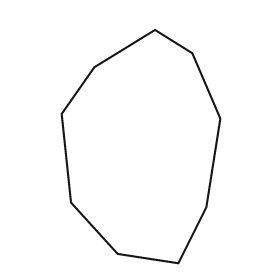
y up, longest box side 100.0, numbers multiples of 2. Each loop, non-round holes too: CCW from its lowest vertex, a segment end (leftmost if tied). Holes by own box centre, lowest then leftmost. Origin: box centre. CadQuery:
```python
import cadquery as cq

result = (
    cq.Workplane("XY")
    .moveTo(16.0, -50.0)
    .lineTo(28.0, -26.0)
    .lineTo(34.0, 12.0)
    .lineTo(22.0, 40.0)
    .lineTo(6.0, 50.0)
    .lineTo(-20.0, 34.0)
    .lineTo(-34.0, 14.0)
    .lineTo(-30.0, -24.0)
    .lineTo(-10.0, -46.0)
    .close()
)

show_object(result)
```